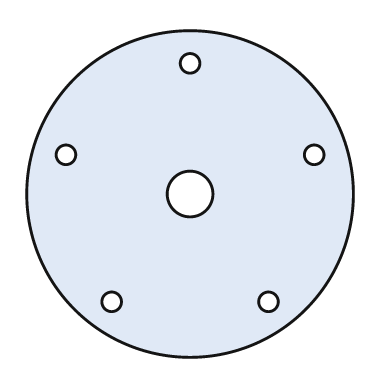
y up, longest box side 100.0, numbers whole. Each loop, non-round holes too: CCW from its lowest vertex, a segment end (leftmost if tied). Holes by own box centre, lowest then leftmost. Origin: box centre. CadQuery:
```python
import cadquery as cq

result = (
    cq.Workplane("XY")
    .moveTo(0.0, 0.0)
    .circle(50.0)
    .moveTo(-24.0, -33.0)
    .circle(3.0)
    .moveTo(24.0, -33.0)
    .circle(3.0)
    .moveTo(0.0, 0.0)
    .circle(7.0)
    .moveTo(-38.0, 12.0)
    .circle(3.0)
    .moveTo(38.0, 12.0)
    .circle(3.0)
    .moveTo(0.0, 40.0)
    .circle(3.0)
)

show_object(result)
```